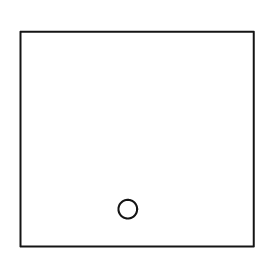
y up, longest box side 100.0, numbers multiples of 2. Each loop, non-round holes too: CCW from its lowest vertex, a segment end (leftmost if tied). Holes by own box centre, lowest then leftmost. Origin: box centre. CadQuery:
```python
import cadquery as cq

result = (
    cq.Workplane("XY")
    .moveTo(-50.0, -46.0)
    .lineTo(50.0, -46.0)
    .lineTo(50.0, 46.0)
    .lineTo(-50.0, 46.0)
    .close()
    .moveTo(-4.0, -30.0)
    .circle(4.0)
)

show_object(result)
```